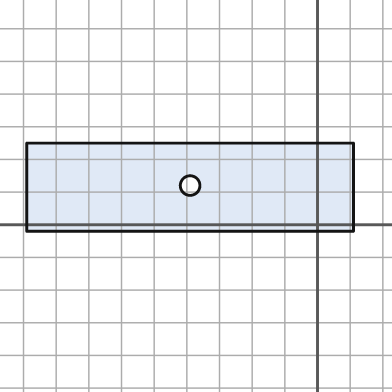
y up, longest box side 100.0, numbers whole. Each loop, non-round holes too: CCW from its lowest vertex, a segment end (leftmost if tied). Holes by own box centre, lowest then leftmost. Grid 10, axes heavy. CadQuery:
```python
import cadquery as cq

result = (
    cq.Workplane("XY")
    .moveTo(-89.0, -2.0)
    .lineTo(11.0, -2.0)
    .lineTo(11.0, 25.0)
    .lineTo(-89.0, 25.0)
    .close()
    .moveTo(-39.0, 12.0)
    .circle(3.0)
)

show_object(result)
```